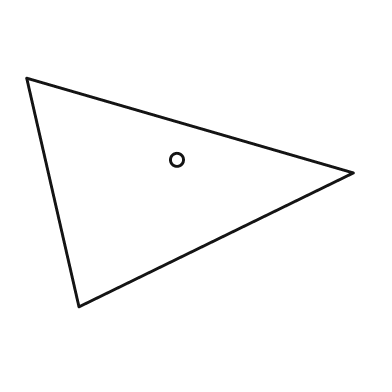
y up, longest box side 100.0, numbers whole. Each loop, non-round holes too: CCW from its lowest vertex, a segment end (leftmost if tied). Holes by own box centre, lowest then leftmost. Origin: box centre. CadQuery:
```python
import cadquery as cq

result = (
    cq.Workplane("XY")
    .moveTo(-34.0, -35.0)
    .lineTo(50.0, 6.0)
    .lineTo(-50.0, 35.0)
    .close()
    .moveTo(-4.0, 10.0)
    .circle(2.0)
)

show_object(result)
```